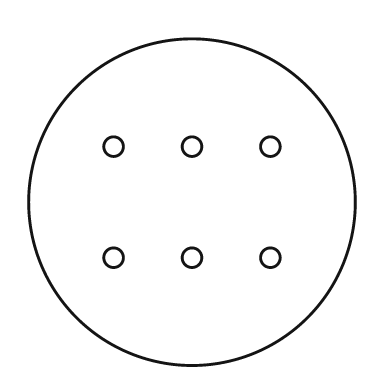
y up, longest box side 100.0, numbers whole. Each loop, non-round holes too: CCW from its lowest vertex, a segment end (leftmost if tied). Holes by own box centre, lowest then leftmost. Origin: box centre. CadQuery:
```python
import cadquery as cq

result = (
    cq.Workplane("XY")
    .moveTo(0.0, 0.0)
    .circle(50.0)
    .moveTo(-24.0, -17.0)
    .circle(3.0)
    .moveTo(0.0, -17.0)
    .circle(3.0)
    .moveTo(24.0, -17.0)
    .circle(3.0)
    .moveTo(-24.0, 17.0)
    .circle(3.0)
    .moveTo(0.0, 17.0)
    .circle(3.0)
    .moveTo(24.0, 17.0)
    .circle(3.0)
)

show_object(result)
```